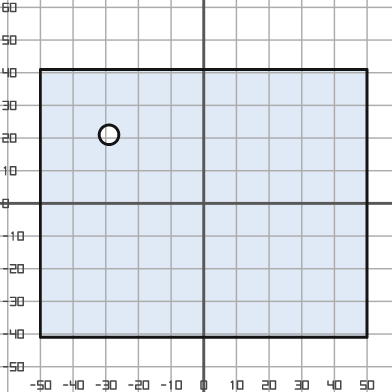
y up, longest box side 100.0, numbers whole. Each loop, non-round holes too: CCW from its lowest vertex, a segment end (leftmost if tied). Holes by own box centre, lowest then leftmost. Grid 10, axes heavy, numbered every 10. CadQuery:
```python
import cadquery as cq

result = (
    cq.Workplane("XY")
    .moveTo(-50.0, -41.0)
    .lineTo(50.0, -41.0)
    .lineTo(50.0, 41.0)
    .lineTo(-50.0, 41.0)
    .close()
    .moveTo(-29.0, 21.0)
    .circle(3.0)
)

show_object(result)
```